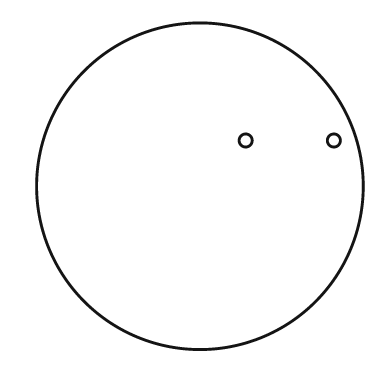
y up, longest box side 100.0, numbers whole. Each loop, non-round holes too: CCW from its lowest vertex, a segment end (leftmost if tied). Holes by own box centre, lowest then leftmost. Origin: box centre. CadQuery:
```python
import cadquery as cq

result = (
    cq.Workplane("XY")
    .moveTo(0.0, 0.0)
    .circle(50.0)
    .moveTo(14.0, 14.0)
    .circle(2.0)
    .moveTo(41.0, 14.0)
    .circle(2.0)
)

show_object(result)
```